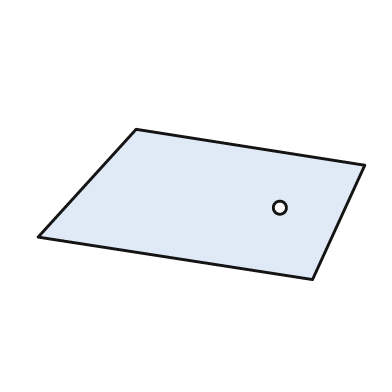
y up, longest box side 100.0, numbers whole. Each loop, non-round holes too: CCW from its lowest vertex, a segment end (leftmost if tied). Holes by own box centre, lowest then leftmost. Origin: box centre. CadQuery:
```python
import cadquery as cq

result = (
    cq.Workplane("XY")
    .moveTo(34.0, -23.0)
    .lineTo(50.0, 12.0)
    .lineTo(-20.0, 23.0)
    .lineTo(-50.0, -10.0)
    .close()
    .moveTo(24.0, -1.0)
    .circle(2.0)
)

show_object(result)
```